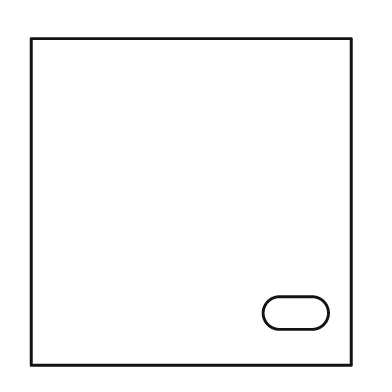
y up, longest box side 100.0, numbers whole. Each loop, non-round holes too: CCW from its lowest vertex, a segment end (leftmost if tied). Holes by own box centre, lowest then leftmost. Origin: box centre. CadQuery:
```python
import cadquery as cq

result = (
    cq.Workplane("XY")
    .moveTo(-49.0, -50.0)
    .lineTo(49.0, -50.0)
    .lineTo(49.0, 50.0)
    .lineTo(-49.0, 50.0)
    .close()
    .moveTo(27.0, -39.0)
    .lineTo(37.0, -39.0)
    .threePointArc((42.0, -34.0), (37.0, -29.0))
    .lineTo(27.0, -29.0)
    .threePointArc((22.0, -34.0), (27.0, -39.0))
    .close()
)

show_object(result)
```